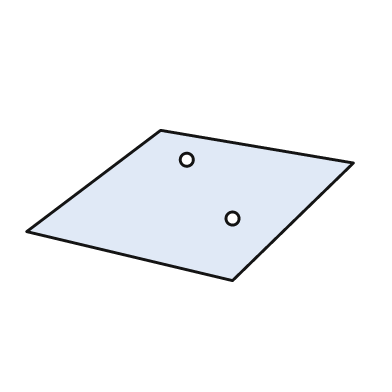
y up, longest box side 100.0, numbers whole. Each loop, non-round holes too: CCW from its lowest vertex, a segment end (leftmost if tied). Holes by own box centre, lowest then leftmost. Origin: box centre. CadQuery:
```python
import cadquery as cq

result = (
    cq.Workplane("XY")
    .moveTo(13.0, -23.0)
    .lineTo(50.0, 13.0)
    .lineTo(-9.0, 23.0)
    .lineTo(-50.0, -8.0)
    .close()
    .moveTo(13.0, -4.0)
    .circle(2.0)
    .moveTo(-1.0, 14.0)
    .circle(2.0)
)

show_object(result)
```